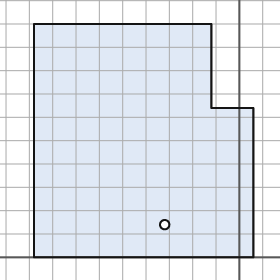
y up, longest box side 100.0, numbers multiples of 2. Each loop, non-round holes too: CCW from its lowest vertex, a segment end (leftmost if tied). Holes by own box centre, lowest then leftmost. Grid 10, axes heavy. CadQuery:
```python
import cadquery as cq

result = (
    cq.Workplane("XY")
    .moveTo(-88.0, 0.0)
    .lineTo(6.0, 0.0)
    .lineTo(6.0, 64.0)
    .lineTo(-12.0, 64.0)
    .lineTo(-12.0, 100.0)
    .lineTo(-88.0, 100.0)
    .close()
    .moveTo(-32.0, 14.0)
    .circle(2.0)
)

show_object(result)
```